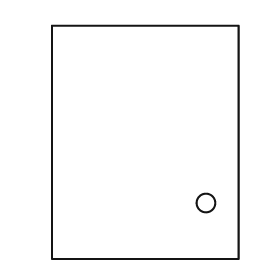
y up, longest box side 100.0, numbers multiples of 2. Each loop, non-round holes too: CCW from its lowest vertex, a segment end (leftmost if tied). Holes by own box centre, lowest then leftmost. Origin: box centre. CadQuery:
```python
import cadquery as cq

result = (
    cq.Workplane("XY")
    .moveTo(-40.0, -50.0)
    .lineTo(40.0, -50.0)
    .lineTo(40.0, 50.0)
    .lineTo(-40.0, 50.0)
    .close()
    .moveTo(26.0, -26.0)
    .circle(4.0)
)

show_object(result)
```